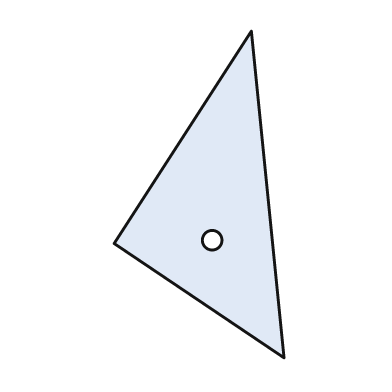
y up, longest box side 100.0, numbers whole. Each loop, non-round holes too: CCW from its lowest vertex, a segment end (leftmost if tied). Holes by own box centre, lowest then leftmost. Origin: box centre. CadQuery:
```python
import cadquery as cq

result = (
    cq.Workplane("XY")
    .moveTo(26.0, -50.0)
    .lineTo(16.0, 50.0)
    .lineTo(-26.0, -15.0)
    .close()
    .moveTo(4.0, -14.0)
    .circle(3.0)
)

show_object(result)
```